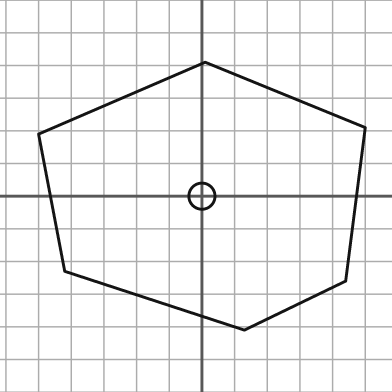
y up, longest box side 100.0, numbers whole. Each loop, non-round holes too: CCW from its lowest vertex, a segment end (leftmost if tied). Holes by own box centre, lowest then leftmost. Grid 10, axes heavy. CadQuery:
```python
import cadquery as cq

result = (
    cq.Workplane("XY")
    .moveTo(13.0, -41.0)
    .lineTo(44.0, -26.0)
    .lineTo(50.0, 21.0)
    .lineTo(1.0, 41.0)
    .lineTo(-50.0, 19.0)
    .lineTo(-42.0, -23.0)
    .close()
    .moveTo(0.0, 0.0)
    .circle(4.0)
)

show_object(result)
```